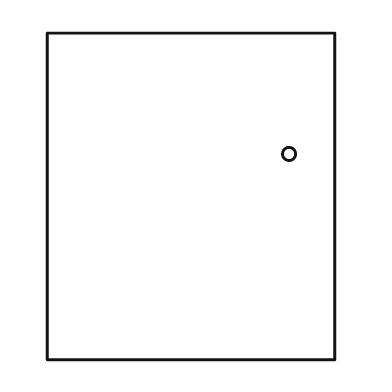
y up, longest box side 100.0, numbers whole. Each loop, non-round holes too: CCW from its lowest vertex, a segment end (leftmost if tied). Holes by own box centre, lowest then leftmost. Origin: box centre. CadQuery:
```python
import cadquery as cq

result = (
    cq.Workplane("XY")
    .moveTo(-44.0, -50.0)
    .lineTo(44.0, -50.0)
    .lineTo(44.0, 50.0)
    .lineTo(-44.0, 50.0)
    .close()
    .moveTo(30.0, 13.0)
    .circle(2.0)
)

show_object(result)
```